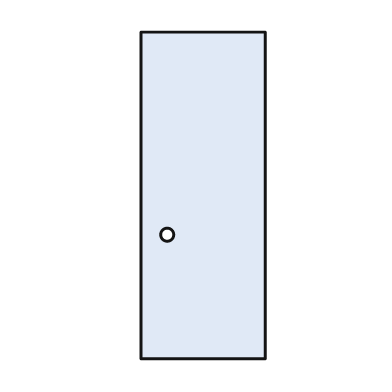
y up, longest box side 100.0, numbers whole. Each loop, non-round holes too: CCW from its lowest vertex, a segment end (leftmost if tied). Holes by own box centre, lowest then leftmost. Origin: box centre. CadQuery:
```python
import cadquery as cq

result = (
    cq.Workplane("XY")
    .moveTo(-19.0, -50.0)
    .lineTo(19.0, -50.0)
    .lineTo(19.0, 50.0)
    .lineTo(-19.0, 50.0)
    .close()
    .moveTo(-11.0, -12.0)
    .circle(2.0)
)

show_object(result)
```